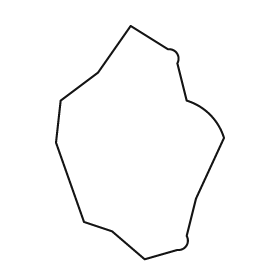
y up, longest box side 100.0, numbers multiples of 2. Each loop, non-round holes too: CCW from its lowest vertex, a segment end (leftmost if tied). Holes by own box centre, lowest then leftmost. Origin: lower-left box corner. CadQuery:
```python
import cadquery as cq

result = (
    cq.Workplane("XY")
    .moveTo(38.0, 0.0)
    .lineTo(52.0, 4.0)
    .threePointArc((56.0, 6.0), (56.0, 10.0))
    .lineTo(60.0, 26.0)
    .lineTo(72.0, 52.0)
    .threePointArc((66.0, 62.0), (56.0, 68.0))
    .lineTo(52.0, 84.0)
    .threePointArc((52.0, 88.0), (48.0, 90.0))
    .lineTo(32.0, 100.0)
    .lineTo(18.0, 80.0)
    .lineTo(2.0, 68.0)
    .lineTo(0.0, 50.0)
    .lineTo(12.0, 16.0)
    .lineTo(24.0, 12.0)
    .close()
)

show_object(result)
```